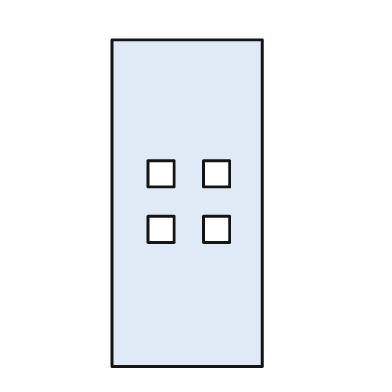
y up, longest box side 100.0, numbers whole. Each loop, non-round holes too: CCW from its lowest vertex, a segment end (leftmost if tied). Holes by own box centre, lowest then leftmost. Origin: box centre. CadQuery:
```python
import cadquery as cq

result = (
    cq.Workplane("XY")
    .moveTo(-23.0, -50.0)
    .lineTo(23.0, -50.0)
    .lineTo(23.0, 50.0)
    .lineTo(-23.0, 50.0)
    .close()
    .moveTo(-12.0, -12.0)
    .lineTo(-4.0, -12.0)
    .lineTo(-4.0, -4.0)
    .lineTo(-12.0, -4.0)
    .close()
    .moveTo(5.0, -12.0)
    .lineTo(13.0, -12.0)
    .lineTo(13.0, -4.0)
    .lineTo(5.0, -4.0)
    .close()
    .moveTo(-12.0, 5.0)
    .lineTo(-4.0, 5.0)
    .lineTo(-4.0, 13.0)
    .lineTo(-12.0, 13.0)
    .close()
    .moveTo(5.0, 5.0)
    .lineTo(13.0, 5.0)
    .lineTo(13.0, 13.0)
    .lineTo(5.0, 13.0)
    .close()
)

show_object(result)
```